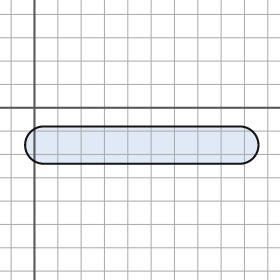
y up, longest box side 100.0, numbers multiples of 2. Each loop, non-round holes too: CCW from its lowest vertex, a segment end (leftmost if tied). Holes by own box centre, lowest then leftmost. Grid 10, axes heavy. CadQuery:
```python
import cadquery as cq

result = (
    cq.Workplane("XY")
    .moveTo(4.0, -24.0)
    .lineTo(88.0, -24.0)
    .threePointArc((96.0, -16.0), (88.0, -8.0))
    .lineTo(4.0, -8.0)
    .threePointArc((-4.0, -16.0), (4.0, -24.0))
    .close()
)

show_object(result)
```